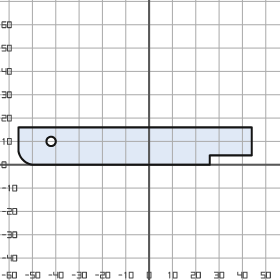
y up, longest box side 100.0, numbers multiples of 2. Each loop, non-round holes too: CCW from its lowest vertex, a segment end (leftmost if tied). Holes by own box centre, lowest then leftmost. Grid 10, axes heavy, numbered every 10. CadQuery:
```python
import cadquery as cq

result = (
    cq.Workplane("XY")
    .moveTo(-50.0, 0.0)
    .lineTo(26.0, 0.0)
    .lineTo(26.0, 4.0)
    .lineTo(44.0, 4.0)
    .lineTo(44.0, 16.0)
    .lineTo(-56.0, 16.0)
    .lineTo(-56.0, 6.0)
    .threePointArc((-54.0, 2.0), (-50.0, 0.0))
    .close()
    .moveTo(-42.0, 10.0)
    .circle(2.0)
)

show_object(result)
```